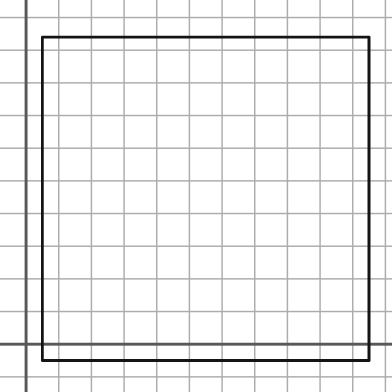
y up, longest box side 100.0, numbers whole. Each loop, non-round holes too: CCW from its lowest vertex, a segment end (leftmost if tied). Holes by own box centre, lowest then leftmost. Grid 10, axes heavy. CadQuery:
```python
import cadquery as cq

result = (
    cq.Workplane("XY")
    .moveTo(5.0, -5.0)
    .lineTo(105.0, -5.0)
    .lineTo(105.0, 94.0)
    .lineTo(5.0, 94.0)
    .close()
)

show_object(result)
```